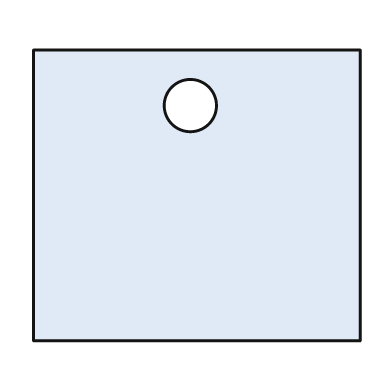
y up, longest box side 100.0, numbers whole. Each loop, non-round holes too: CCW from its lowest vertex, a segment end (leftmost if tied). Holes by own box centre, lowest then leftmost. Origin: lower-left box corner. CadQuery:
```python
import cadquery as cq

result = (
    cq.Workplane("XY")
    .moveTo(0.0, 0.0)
    .lineTo(100.0, 0.0)
    .lineTo(100.0, 89.0)
    .lineTo(0.0, 89.0)
    .close()
    .moveTo(48.0, 72.0)
    .circle(8.0)
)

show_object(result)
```